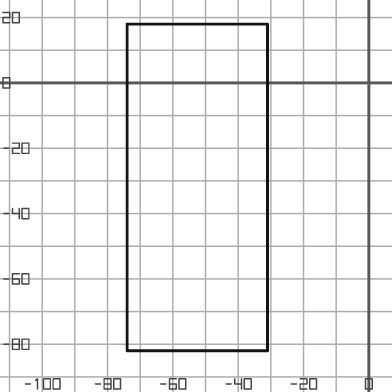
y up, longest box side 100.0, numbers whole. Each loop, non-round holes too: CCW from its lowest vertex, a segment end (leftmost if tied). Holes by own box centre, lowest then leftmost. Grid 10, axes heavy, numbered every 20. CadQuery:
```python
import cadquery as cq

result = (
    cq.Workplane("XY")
    .moveTo(-74.0, -82.0)
    .lineTo(-31.0, -82.0)
    .lineTo(-31.0, 18.0)
    .lineTo(-74.0, 18.0)
    .close()
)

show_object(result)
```